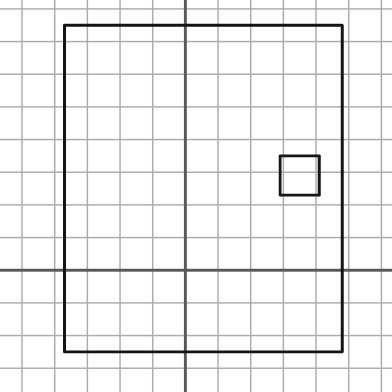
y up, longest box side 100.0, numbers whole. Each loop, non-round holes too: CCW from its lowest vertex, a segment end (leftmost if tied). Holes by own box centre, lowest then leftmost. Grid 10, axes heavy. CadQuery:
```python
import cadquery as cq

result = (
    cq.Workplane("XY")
    .moveTo(-37.0, -25.0)
    .lineTo(48.0, -25.0)
    .lineTo(48.0, 75.0)
    .lineTo(-37.0, 75.0)
    .close()
    .moveTo(29.0, 23.0)
    .lineTo(41.0, 23.0)
    .lineTo(41.0, 35.0)
    .lineTo(29.0, 35.0)
    .close()
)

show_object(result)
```